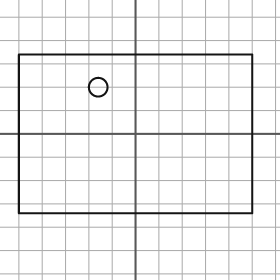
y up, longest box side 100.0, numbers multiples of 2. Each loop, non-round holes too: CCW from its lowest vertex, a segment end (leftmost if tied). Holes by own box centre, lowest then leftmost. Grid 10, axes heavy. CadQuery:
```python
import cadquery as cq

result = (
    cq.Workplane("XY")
    .moveTo(-50.0, -34.0)
    .lineTo(50.0, -34.0)
    .lineTo(50.0, 34.0)
    .lineTo(-50.0, 34.0)
    .close()
    .moveTo(-16.0, 20.0)
    .circle(4.0)
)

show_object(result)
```